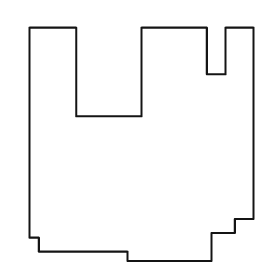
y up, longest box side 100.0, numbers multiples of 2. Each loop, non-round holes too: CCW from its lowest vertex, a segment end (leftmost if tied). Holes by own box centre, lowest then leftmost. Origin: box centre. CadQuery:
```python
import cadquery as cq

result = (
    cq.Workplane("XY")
    .moveTo(-6.0, -50.0)
    .lineTo(30.0, -50.0)
    .lineTo(30.0, -38.0)
    .lineTo(40.0, -38.0)
    .lineTo(40.0, -32.0)
    .lineTo(48.0, -32.0)
    .lineTo(48.0, 50.0)
    .lineTo(36.0, 50.0)
    .lineTo(36.0, 30.0)
    .lineTo(28.0, 30.0)
    .lineTo(28.0, 50.0)
    .lineTo(0.0, 50.0)
    .lineTo(0.0, 12.0)
    .lineTo(-28.0, 12.0)
    .lineTo(-28.0, 50.0)
    .lineTo(-48.0, 50.0)
    .lineTo(-48.0, -40.0)
    .lineTo(-44.0, -40.0)
    .lineTo(-44.0, -46.0)
    .lineTo(-6.0, -46.0)
    .close()
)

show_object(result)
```